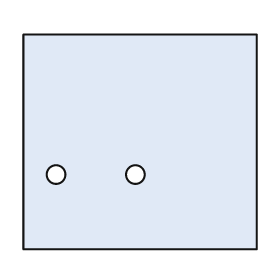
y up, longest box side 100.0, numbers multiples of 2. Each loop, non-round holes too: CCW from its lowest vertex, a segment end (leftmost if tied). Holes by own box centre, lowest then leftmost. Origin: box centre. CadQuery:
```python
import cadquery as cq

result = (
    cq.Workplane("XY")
    .moveTo(-50.0, -46.0)
    .lineTo(50.0, -46.0)
    .lineTo(50.0, 46.0)
    .lineTo(-50.0, 46.0)
    .close()
    .moveTo(-36.0, -14.0)
    .circle(4.0)
    .moveTo(-2.0, -14.0)
    .circle(4.0)
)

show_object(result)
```